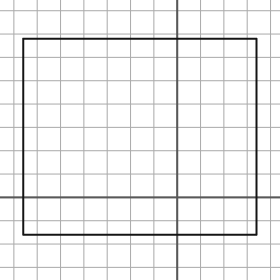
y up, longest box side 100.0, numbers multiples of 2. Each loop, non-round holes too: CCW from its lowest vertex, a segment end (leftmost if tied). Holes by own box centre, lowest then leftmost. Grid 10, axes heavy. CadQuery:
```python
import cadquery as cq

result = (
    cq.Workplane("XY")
    .moveTo(-66.0, -16.0)
    .lineTo(34.0, -16.0)
    .lineTo(34.0, 68.0)
    .lineTo(-66.0, 68.0)
    .close()
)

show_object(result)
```